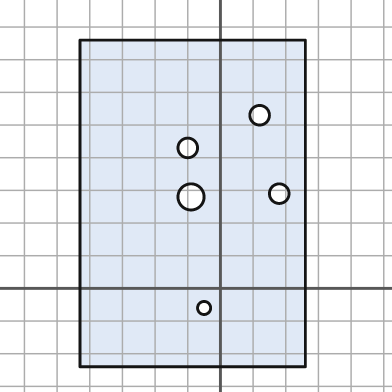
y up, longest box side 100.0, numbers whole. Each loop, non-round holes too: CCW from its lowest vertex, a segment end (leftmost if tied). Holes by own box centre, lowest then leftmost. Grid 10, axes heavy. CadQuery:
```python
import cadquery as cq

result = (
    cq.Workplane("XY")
    .moveTo(-43.0, -24.0)
    .lineTo(26.0, -24.0)
    .lineTo(26.0, 76.0)
    .lineTo(-43.0, 76.0)
    .close()
    .moveTo(-5.0, -6.0)
    .circle(2.0)
    .moveTo(-9.0, 28.0)
    .circle(4.0)
    .moveTo(18.0, 29.0)
    .circle(3.0)
    .moveTo(-10.0, 43.0)
    .circle(3.0)
    .moveTo(12.0, 53.0)
    .circle(3.0)
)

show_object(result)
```